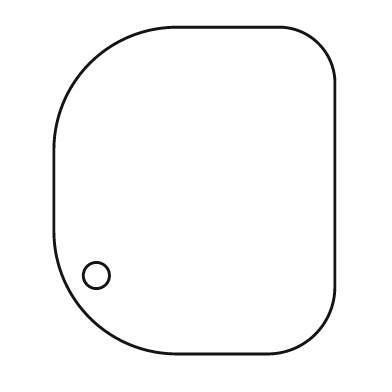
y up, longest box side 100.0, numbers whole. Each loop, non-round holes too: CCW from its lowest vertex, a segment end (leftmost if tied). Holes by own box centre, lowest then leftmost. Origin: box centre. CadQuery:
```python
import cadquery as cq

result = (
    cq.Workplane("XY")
    .moveTo(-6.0, -50.0)
    .lineTo(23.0, -50.0)
    .threePointArc((37.0, -44.0), (43.0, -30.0))
    .lineTo(43.0, 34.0)
    .threePointArc((38.0, 45.0), (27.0, 50.0))
    .lineTo(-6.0, 50.0)
    .threePointArc((-32.0, 39.0), (-43.0, 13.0))
    .lineTo(-43.0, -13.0)
    .threePointArc((-32.0, -39.0), (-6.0, -50.0))
    .close()
    .moveTo(-30.0, -26.0)
    .circle(4.0)
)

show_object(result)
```